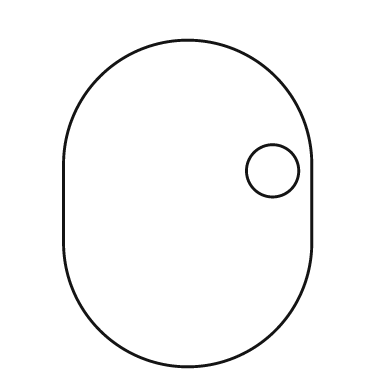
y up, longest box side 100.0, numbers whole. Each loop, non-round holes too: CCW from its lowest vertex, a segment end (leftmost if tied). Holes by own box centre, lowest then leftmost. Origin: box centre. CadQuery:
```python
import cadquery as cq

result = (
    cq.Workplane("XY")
    .moveTo(-38.0, -12.0)
    .threePointArc((0.0, -50.0), (38.0, -12.0))
    .lineTo(38.0, 12.0)
    .threePointArc((0.0, 50.0), (-38.0, 12.0))
    .close()
    .moveTo(26.0, 10.0)
    .circle(8.0)
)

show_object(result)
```